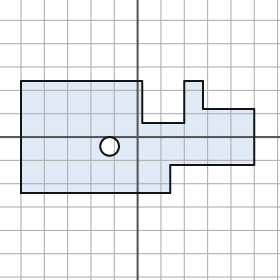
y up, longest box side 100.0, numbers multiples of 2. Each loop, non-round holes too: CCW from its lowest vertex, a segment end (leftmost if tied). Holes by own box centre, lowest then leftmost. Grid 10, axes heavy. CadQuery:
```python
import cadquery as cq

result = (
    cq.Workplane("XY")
    .moveTo(-50.0, -24.0)
    .lineTo(14.0, -24.0)
    .lineTo(14.0, -12.0)
    .lineTo(50.0, -12.0)
    .lineTo(50.0, 12.0)
    .lineTo(28.0, 12.0)
    .lineTo(28.0, 24.0)
    .lineTo(20.0, 24.0)
    .lineTo(20.0, 6.0)
    .lineTo(2.0, 6.0)
    .lineTo(2.0, 24.0)
    .lineTo(-50.0, 24.0)
    .close()
    .moveTo(-12.0, -4.0)
    .circle(4.0)
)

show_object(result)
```